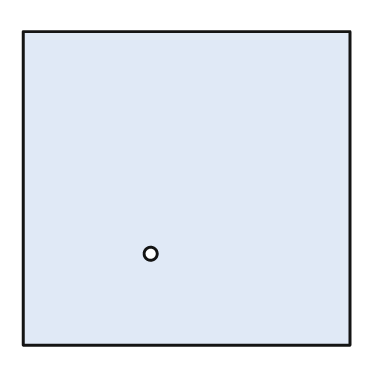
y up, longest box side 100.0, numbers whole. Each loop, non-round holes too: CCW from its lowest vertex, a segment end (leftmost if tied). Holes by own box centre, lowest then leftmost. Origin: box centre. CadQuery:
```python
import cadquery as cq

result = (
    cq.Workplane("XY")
    .moveTo(-50.0, -48.0)
    .lineTo(50.0, -48.0)
    .lineTo(50.0, 48.0)
    .lineTo(-50.0, 48.0)
    .close()
    .moveTo(-11.0, -20.0)
    .circle(2.0)
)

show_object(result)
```